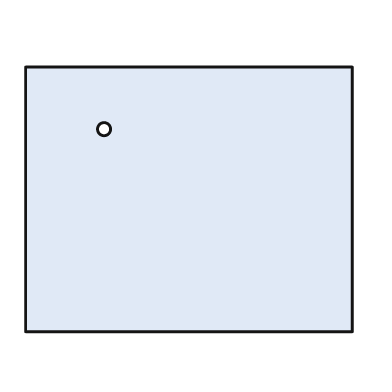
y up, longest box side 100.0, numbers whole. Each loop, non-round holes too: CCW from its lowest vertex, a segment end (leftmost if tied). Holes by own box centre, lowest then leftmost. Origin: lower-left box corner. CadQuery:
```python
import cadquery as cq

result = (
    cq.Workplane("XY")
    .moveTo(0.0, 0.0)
    .lineTo(100.0, 0.0)
    .lineTo(100.0, 81.0)
    .lineTo(0.0, 81.0)
    .close()
    .moveTo(24.0, 62.0)
    .circle(2.0)
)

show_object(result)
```